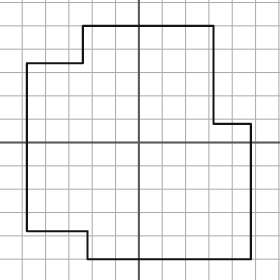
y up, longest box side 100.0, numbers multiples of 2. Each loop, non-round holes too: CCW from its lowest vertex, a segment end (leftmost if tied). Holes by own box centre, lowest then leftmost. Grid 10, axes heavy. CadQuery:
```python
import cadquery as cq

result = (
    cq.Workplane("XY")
    .moveTo(-22.0, -50.0)
    .lineTo(48.0, -50.0)
    .lineTo(48.0, 8.0)
    .lineTo(32.0, 8.0)
    .lineTo(32.0, 50.0)
    .lineTo(-24.0, 50.0)
    .lineTo(-24.0, 34.0)
    .lineTo(-48.0, 34.0)
    .lineTo(-48.0, -38.0)
    .lineTo(-22.0, -38.0)
    .close()
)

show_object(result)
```